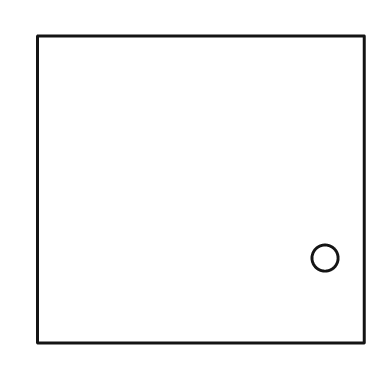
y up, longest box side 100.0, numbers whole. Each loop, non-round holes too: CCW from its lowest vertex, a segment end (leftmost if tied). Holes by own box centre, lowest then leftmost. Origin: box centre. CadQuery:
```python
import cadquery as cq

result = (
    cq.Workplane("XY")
    .moveTo(-50.0, -47.0)
    .lineTo(50.0, -47.0)
    .lineTo(50.0, 47.0)
    .lineTo(-50.0, 47.0)
    .close()
    .moveTo(38.0, -21.0)
    .circle(4.0)
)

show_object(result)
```